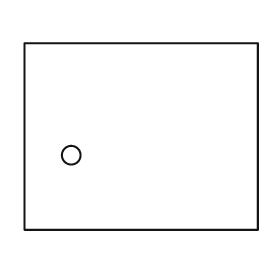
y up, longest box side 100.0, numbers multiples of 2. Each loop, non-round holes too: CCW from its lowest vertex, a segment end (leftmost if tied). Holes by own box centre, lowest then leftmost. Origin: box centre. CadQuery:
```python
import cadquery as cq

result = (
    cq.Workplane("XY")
    .moveTo(-50.0, -40.0)
    .lineTo(50.0, -40.0)
    .lineTo(50.0, 40.0)
    .lineTo(-50.0, 40.0)
    .close()
    .moveTo(-30.0, -8.0)
    .circle(4.0)
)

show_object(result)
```